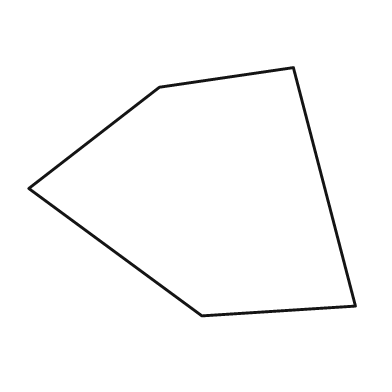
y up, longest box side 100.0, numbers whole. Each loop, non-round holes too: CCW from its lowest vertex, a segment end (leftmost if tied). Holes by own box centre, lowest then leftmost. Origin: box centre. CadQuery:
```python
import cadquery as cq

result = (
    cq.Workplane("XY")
    .moveTo(3.0, -38.0)
    .lineTo(50.0, -35.0)
    .lineTo(31.0, 38.0)
    .lineTo(-10.0, 32.0)
    .lineTo(-50.0, 1.0)
    .close()
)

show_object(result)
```